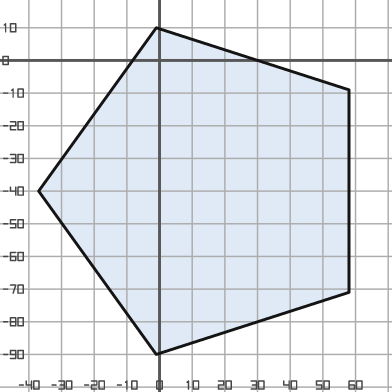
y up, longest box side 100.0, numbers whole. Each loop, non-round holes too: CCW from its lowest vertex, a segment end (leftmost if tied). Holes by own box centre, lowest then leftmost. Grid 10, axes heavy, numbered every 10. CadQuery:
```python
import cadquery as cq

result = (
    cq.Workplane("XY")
    .moveTo(-1.0, -90.0)
    .lineTo(58.0, -71.0)
    .lineTo(58.0, -9.0)
    .lineTo(-1.0, 10.0)
    .lineTo(-37.0, -40.0)
    .close()
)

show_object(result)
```